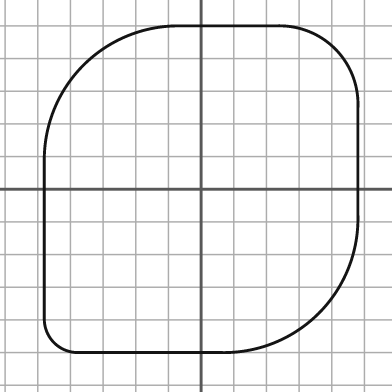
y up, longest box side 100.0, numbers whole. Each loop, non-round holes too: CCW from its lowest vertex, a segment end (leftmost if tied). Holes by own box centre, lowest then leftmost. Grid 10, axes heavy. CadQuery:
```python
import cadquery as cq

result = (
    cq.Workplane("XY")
    .moveTo(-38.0, -50.0)
    .lineTo(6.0, -50.0)
    .threePointArc((36.0, -38.0), (48.0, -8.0))
    .lineTo(48.0, 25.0)
    .threePointArc((41.0, 43.0), (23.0, 50.0))
    .lineTo(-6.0, 50.0)
    .threePointArc((-36.0, 38.0), (-48.0, 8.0))
    .lineTo(-48.0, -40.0)
    .threePointArc((-45.0, -47.0), (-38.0, -50.0))
    .close()
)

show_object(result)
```